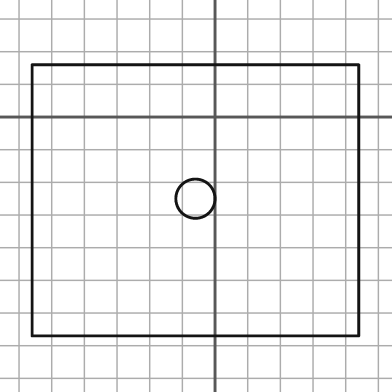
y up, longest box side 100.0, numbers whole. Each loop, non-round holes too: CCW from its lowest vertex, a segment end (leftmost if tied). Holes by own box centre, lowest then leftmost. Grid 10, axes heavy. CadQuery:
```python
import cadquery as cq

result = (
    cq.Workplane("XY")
    .moveTo(-56.0, -67.0)
    .lineTo(44.0, -67.0)
    .lineTo(44.0, 16.0)
    .lineTo(-56.0, 16.0)
    .close()
    .moveTo(-6.0, -25.0)
    .circle(6.0)
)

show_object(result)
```